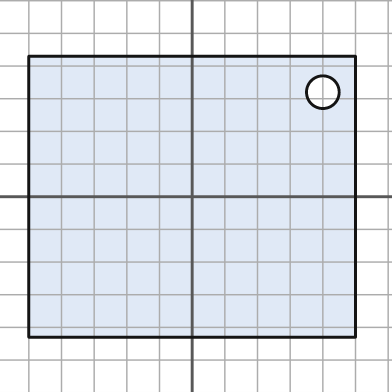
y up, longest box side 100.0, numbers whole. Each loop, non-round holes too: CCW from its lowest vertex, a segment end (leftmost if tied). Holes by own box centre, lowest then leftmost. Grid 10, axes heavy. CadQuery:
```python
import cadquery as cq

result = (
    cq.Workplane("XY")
    .moveTo(-50.0, -43.0)
    .lineTo(50.0, -43.0)
    .lineTo(50.0, 43.0)
    .lineTo(-50.0, 43.0)
    .close()
    .moveTo(40.0, 32.0)
    .circle(5.0)
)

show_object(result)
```